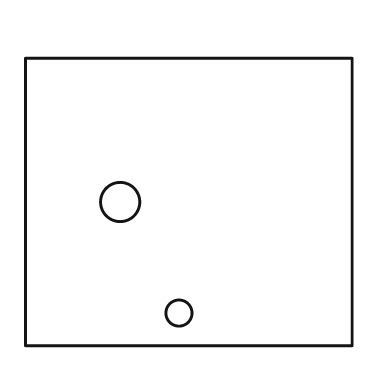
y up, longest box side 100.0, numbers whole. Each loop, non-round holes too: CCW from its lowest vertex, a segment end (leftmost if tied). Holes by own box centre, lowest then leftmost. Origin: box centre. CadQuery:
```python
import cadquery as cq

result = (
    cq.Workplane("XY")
    .moveTo(-50.0, -44.0)
    .lineTo(50.0, -44.0)
    .lineTo(50.0, 44.0)
    .lineTo(-50.0, 44.0)
    .close()
    .moveTo(-3.0, -34.0)
    .circle(4.0)
    .moveTo(-21.0, 0.0)
    .circle(6.0)
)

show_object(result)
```